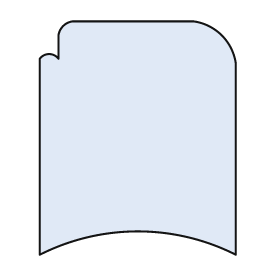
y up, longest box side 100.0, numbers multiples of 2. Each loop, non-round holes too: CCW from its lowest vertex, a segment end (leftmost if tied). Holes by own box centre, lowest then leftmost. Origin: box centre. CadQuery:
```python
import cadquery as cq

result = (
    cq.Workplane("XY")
    .moveTo(-42.0, -50.0)
    .threePointArc((0.0, -40.0), (42.0, -50.0))
    .lineTo(42.0, 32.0)
    .threePointArc((36.0, 44.0), (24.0, 50.0))
    .lineTo(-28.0, 50.0)
    .threePointArc((-32.0, 48.0), (-34.0, 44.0))
    .lineTo(-34.0, 34.0)
    .threePointArc((-38.0, 36.0), (-42.0, 34.0))
    .close()
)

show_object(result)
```